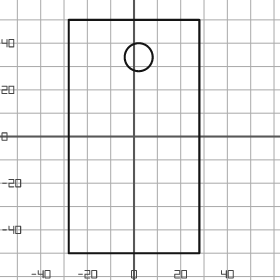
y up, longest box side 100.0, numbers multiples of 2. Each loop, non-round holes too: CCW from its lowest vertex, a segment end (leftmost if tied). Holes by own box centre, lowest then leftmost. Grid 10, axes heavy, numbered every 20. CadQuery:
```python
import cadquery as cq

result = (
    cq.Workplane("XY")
    .moveTo(-28.0, -50.0)
    .lineTo(28.0, -50.0)
    .lineTo(28.0, 50.0)
    .lineTo(-28.0, 50.0)
    .close()
    .moveTo(2.0, 34.0)
    .circle(6.0)
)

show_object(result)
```